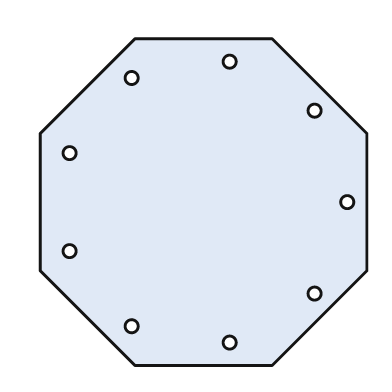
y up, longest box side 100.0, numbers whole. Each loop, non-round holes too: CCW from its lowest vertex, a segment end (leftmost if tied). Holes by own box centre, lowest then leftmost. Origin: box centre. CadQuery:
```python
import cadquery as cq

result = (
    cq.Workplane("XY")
    .moveTo(-21.0, -50.0)
    .lineTo(21.0, -50.0)
    .lineTo(50.0, -21.0)
    .lineTo(50.0, 21.0)
    .lineTo(21.0, 50.0)
    .lineTo(-21.0, 50.0)
    .lineTo(-50.0, 21.0)
    .lineTo(-50.0, -21.0)
    .close()
    .moveTo(8.0, -43.0)
    .circle(2.0)
    .moveTo(-22.0, -38.0)
    .circle(2.0)
    .moveTo(34.0, -28.0)
    .circle(2.0)
    .moveTo(-41.0, -15.0)
    .circle(2.0)
    .moveTo(44.0, 0.0)
    .circle(2.0)
    .moveTo(-41.0, 15.0)
    .circle(2.0)
    .moveTo(34.0, 28.0)
    .circle(2.0)
    .moveTo(-22.0, 38.0)
    .circle(2.0)
    .moveTo(8.0, 43.0)
    .circle(2.0)
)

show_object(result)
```